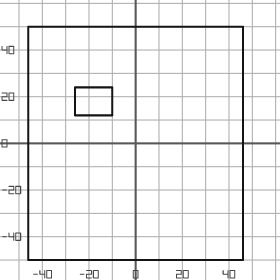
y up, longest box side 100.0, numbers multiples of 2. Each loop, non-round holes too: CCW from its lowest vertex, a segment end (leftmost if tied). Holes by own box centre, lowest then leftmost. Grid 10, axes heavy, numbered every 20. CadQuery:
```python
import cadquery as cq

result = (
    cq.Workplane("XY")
    .moveTo(-46.0, -50.0)
    .lineTo(46.0, -50.0)
    .lineTo(46.0, 50.0)
    .lineTo(-46.0, 50.0)
    .close()
    .moveTo(-26.0, 12.0)
    .lineTo(-10.0, 12.0)
    .lineTo(-10.0, 24.0)
    .lineTo(-26.0, 24.0)
    .close()
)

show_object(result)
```